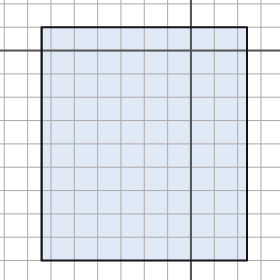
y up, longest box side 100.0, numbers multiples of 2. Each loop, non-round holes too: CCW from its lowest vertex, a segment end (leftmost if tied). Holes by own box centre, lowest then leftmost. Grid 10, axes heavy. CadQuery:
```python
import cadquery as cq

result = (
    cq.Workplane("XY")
    .moveTo(-64.0, -90.0)
    .lineTo(24.0, -90.0)
    .lineTo(24.0, 10.0)
    .lineTo(-64.0, 10.0)
    .close()
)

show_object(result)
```